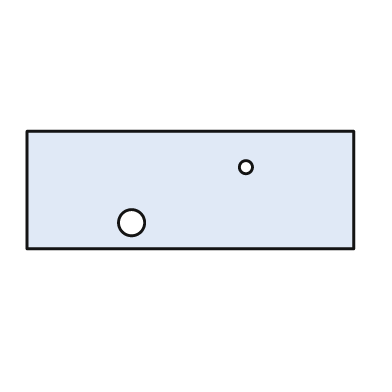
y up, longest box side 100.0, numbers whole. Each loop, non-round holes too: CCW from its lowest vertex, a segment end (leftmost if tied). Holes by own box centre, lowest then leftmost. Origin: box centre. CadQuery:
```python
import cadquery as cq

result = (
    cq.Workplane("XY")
    .moveTo(-50.0, -18.0)
    .lineTo(50.0, -18.0)
    .lineTo(50.0, 18.0)
    .lineTo(-50.0, 18.0)
    .close()
    .moveTo(-18.0, -10.0)
    .circle(4.0)
    .moveTo(17.0, 7.0)
    .circle(2.0)
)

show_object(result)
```